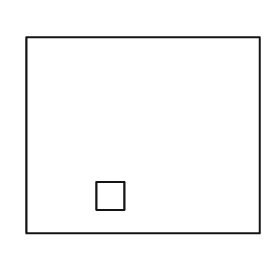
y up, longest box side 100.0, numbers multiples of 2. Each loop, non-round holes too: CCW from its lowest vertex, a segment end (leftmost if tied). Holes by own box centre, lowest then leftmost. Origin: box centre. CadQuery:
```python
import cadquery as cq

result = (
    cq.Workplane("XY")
    .moveTo(-50.0, -42.0)
    .lineTo(50.0, -42.0)
    .lineTo(50.0, 42.0)
    .lineTo(-50.0, 42.0)
    .close()
    .moveTo(-20.0, -32.0)
    .lineTo(-8.0, -32.0)
    .lineTo(-8.0, -20.0)
    .lineTo(-20.0, -20.0)
    .close()
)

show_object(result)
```